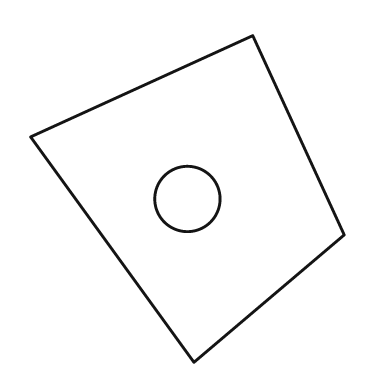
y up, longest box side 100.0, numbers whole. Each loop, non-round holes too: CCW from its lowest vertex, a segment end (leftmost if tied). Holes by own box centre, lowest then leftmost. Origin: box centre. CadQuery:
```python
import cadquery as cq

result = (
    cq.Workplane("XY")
    .moveTo(2.0, -50.0)
    .lineTo(48.0, -11.0)
    .lineTo(20.0, 50.0)
    .lineTo(-48.0, 19.0)
    .close()
    .moveTo(0.0, 0.0)
    .circle(10.0)
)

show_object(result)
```